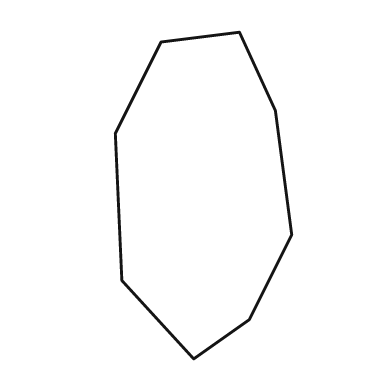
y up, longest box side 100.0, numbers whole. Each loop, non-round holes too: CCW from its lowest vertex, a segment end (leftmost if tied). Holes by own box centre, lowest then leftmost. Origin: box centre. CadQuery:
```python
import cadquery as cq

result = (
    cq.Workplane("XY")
    .moveTo(-3.0, -50.0)
    .lineTo(14.0, -38.0)
    .lineTo(27.0, -12.0)
    .lineTo(22.0, 26.0)
    .lineTo(11.0, 50.0)
    .lineTo(-13.0, 47.0)
    .lineTo(-27.0, 19.0)
    .lineTo(-25.0, -26.0)
    .close()
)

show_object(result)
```